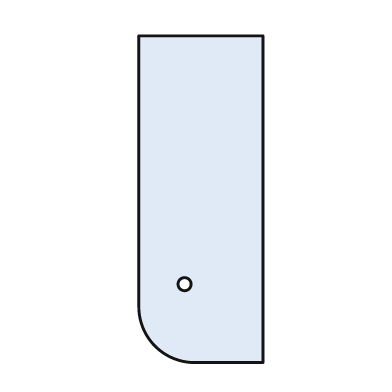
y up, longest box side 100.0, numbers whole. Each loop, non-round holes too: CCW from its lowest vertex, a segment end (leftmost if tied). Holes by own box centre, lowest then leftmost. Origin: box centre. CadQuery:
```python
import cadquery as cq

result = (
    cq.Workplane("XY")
    .moveTo(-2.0, -50.0)
    .lineTo(19.0, -50.0)
    .lineTo(19.0, 50.0)
    .lineTo(-19.0, 50.0)
    .lineTo(-19.0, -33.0)
    .threePointArc((-14.0, -45.0), (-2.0, -50.0))
    .close()
    .moveTo(-5.0, -26.0)
    .circle(2.0)
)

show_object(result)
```